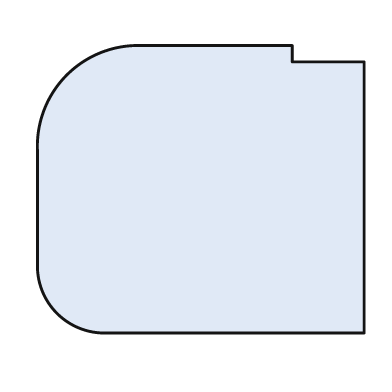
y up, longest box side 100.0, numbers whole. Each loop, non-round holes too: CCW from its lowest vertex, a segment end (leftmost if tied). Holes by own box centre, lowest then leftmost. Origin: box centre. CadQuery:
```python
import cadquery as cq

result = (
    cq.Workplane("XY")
    .moveTo(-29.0, -44.0)
    .lineTo(50.0, -44.0)
    .lineTo(50.0, 39.0)
    .lineTo(28.0, 39.0)
    .lineTo(28.0, 44.0)
    .lineTo(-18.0, 44.0)
    .threePointArc((-41.0, 35.0), (-50.0, 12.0))
    .lineTo(-50.0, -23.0)
    .threePointArc((-44.0, -38.0), (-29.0, -44.0))
    .close()
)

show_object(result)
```